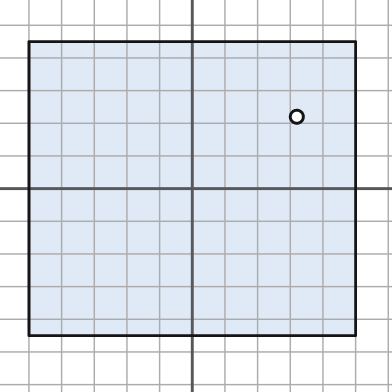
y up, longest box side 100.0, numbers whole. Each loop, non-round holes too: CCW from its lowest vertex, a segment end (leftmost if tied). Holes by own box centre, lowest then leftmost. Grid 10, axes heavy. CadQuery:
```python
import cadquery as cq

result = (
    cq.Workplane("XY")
    .moveTo(-50.0, -45.0)
    .lineTo(50.0, -45.0)
    .lineTo(50.0, 45.0)
    .lineTo(-50.0, 45.0)
    .close()
    .moveTo(32.0, 22.0)
    .circle(2.0)
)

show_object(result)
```